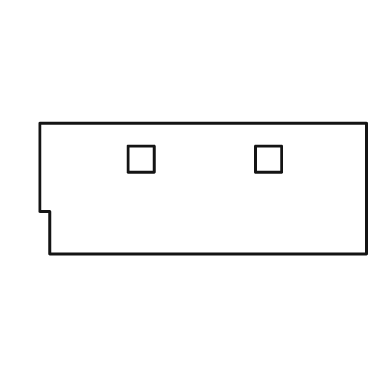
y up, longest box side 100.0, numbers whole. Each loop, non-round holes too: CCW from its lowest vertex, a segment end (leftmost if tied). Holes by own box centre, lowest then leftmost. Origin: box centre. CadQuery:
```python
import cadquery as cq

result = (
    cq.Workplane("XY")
    .moveTo(-47.0, -20.0)
    .lineTo(50.0, -20.0)
    .lineTo(50.0, 20.0)
    .lineTo(-50.0, 20.0)
    .lineTo(-50.0, -7.0)
    .lineTo(-47.0, -7.0)
    .close()
    .moveTo(-23.0, 5.0)
    .lineTo(-15.0, 5.0)
    .lineTo(-15.0, 13.0)
    .lineTo(-23.0, 13.0)
    .close()
    .moveTo(16.0, 5.0)
    .lineTo(24.0, 5.0)
    .lineTo(24.0, 13.0)
    .lineTo(16.0, 13.0)
    .close()
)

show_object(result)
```